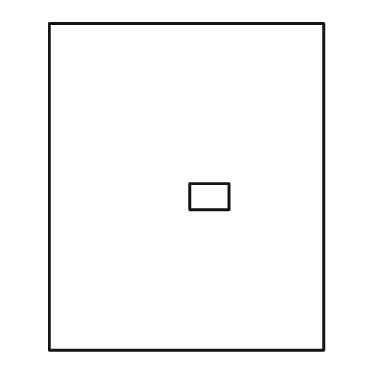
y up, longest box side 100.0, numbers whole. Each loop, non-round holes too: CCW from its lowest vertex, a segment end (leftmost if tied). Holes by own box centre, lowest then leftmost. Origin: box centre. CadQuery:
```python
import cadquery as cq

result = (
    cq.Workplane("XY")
    .moveTo(-42.0, -50.0)
    .lineTo(42.0, -50.0)
    .lineTo(42.0, 50.0)
    .lineTo(-42.0, 50.0)
    .close()
    .moveTo(1.0, -7.0)
    .lineTo(13.0, -7.0)
    .lineTo(13.0, 1.0)
    .lineTo(1.0, 1.0)
    .close()
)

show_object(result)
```